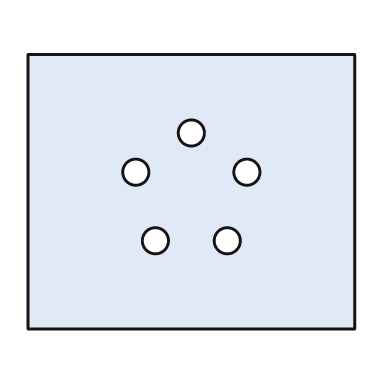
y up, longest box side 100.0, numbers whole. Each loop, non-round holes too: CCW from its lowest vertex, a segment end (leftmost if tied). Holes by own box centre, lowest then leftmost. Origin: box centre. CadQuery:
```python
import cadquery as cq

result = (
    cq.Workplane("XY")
    .moveTo(-50.0, -42.0)
    .lineTo(50.0, -42.0)
    .lineTo(50.0, 42.0)
    .lineTo(-50.0, 42.0)
    .close()
    .moveTo(-11.0, -15.0)
    .circle(4.0)
    .moveTo(11.0, -15.0)
    .circle(4.0)
    .moveTo(-17.0, 6.0)
    .circle(4.0)
    .moveTo(17.0, 6.0)
    .circle(4.0)
    .moveTo(0.0, 18.0)
    .circle(4.0)
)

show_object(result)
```